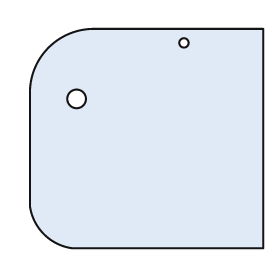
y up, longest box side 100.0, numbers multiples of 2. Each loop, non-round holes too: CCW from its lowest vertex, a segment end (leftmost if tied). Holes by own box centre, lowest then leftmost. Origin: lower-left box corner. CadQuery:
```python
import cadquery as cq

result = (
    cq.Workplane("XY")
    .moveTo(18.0, 0.0)
    .lineTo(100.0, 0.0)
    .lineTo(100.0, 94.0)
    .lineTo(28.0, 94.0)
    .threePointArc((8.0, 86.0), (0.0, 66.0))
    .lineTo(0.0, 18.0)
    .threePointArc((6.0, 6.0), (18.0, 0.0))
    .close()
    .moveTo(20.0, 64.0)
    .circle(4.0)
    .moveTo(66.0, 88.0)
    .circle(2.0)
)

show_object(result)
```